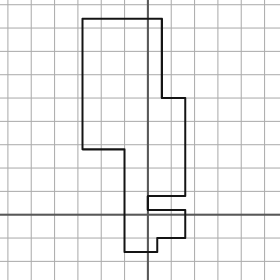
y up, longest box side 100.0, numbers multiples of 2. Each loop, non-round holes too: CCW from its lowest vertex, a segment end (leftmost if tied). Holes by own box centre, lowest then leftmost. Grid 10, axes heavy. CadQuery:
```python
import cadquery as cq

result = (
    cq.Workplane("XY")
    .moveTo(-10.0, -16.0)
    .lineTo(4.0, -16.0)
    .lineTo(4.0, -10.0)
    .lineTo(16.0, -10.0)
    .lineTo(16.0, 2.0)
    .lineTo(0.0, 2.0)
    .lineTo(0.0, 8.0)
    .lineTo(16.0, 8.0)
    .lineTo(16.0, 50.0)
    .lineTo(6.0, 50.0)
    .lineTo(6.0, 84.0)
    .lineTo(-28.0, 84.0)
    .lineTo(-28.0, 28.0)
    .lineTo(-10.0, 28.0)
    .close()
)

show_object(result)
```